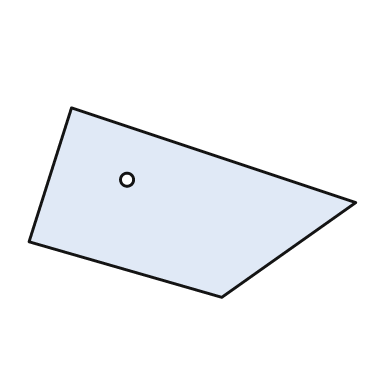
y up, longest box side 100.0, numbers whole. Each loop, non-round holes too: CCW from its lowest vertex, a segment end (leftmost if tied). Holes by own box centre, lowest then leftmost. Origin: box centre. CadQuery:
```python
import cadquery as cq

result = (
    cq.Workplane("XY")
    .moveTo(9.0, -29.0)
    .lineTo(50.0, 0.0)
    .lineTo(-37.0, 29.0)
    .lineTo(-50.0, -12.0)
    .close()
    .moveTo(-20.0, 7.0)
    .circle(2.0)
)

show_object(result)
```